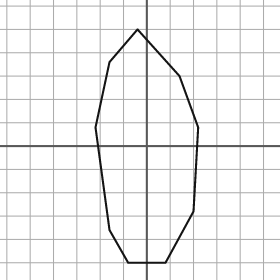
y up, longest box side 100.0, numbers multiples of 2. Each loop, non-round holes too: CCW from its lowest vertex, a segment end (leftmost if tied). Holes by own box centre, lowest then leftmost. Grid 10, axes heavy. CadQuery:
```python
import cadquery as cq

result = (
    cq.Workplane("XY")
    .moveTo(-8.0, -50.0)
    .lineTo(8.0, -50.0)
    .lineTo(20.0, -28.0)
    .lineTo(22.0, 8.0)
    .lineTo(14.0, 30.0)
    .lineTo(-4.0, 50.0)
    .lineTo(-16.0, 36.0)
    .lineTo(-22.0, 8.0)
    .lineTo(-16.0, -36.0)
    .close()
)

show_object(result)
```